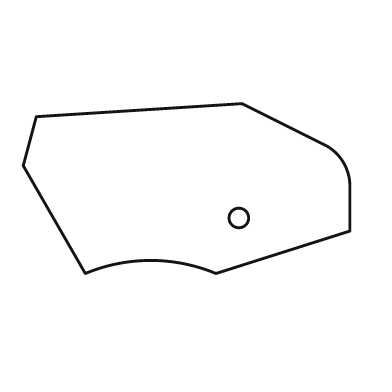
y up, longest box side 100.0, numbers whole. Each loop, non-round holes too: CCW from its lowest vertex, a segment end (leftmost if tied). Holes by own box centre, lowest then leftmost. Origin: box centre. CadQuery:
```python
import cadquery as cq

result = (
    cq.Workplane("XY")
    .moveTo(-31.0, -26.0)
    .threePointArc((-11.0, -22.0), (9.0, -26.0))
    .lineTo(50.0, -13.0)
    .lineTo(50.0, 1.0)
    .threePointArc((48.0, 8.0), (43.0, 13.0))
    .lineTo(17.0, 26.0)
    .lineTo(-46.0, 22.0)
    .lineTo(-50.0, 7.0)
    .close()
    .moveTo(16.0, -9.0)
    .circle(3.0)
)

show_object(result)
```